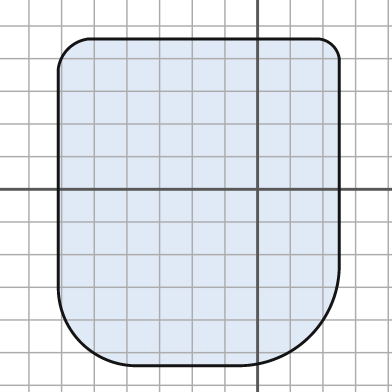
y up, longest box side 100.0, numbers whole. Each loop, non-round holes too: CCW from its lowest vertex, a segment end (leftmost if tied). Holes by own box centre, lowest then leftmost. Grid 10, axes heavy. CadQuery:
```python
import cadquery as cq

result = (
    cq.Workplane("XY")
    .moveTo(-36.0, -54.0)
    .lineTo(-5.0, -54.0)
    .threePointArc((16.0, -45.0), (25.0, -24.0))
    .lineTo(25.0, 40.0)
    .threePointArc((23.0, 44.0), (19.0, 46.0))
    .lineTo(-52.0, 46.0)
    .threePointArc((-58.0, 43.0), (-61.0, 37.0))
    .lineTo(-61.0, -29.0)
    .threePointArc((-54.0, -47.0), (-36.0, -54.0))
    .close()
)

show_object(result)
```